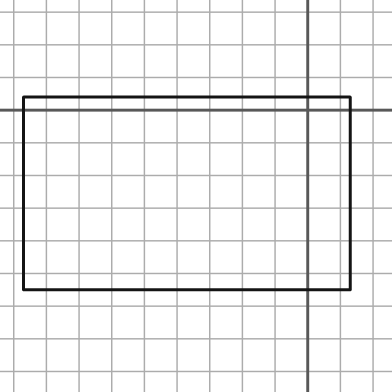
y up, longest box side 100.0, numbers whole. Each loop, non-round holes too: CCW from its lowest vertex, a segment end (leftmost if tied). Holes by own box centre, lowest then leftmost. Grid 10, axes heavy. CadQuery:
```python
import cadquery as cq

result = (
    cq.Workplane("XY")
    .moveTo(-87.0, -55.0)
    .lineTo(13.0, -55.0)
    .lineTo(13.0, 4.0)
    .lineTo(-87.0, 4.0)
    .close()
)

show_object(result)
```